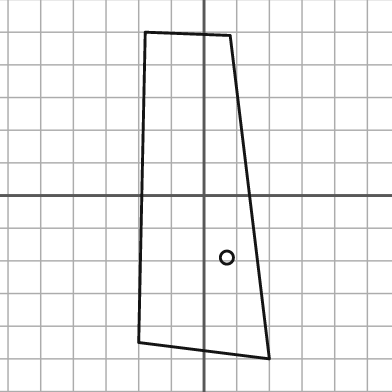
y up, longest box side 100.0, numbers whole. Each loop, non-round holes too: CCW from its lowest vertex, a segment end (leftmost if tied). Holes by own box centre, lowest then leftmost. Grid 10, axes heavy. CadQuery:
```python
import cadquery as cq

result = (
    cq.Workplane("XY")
    .moveTo(20.0, -50.0)
    .lineTo(8.0, 49.0)
    .lineTo(-18.0, 50.0)
    .lineTo(-20.0, -45.0)
    .close()
    .moveTo(7.0, -19.0)
    .circle(2.0)
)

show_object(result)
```